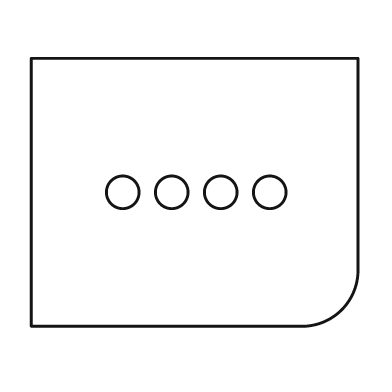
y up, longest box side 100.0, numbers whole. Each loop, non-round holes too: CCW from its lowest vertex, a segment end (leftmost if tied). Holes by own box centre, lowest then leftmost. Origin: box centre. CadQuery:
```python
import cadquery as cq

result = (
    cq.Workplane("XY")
    .moveTo(-50.0, -41.0)
    .lineTo(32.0, -41.0)
    .threePointArc((45.0, -36.0), (50.0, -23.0))
    .lineTo(50.0, 41.0)
    .lineTo(-50.0, 41.0)
    .close()
    .moveTo(-22.0, 0.0)
    .circle(5.0)
    .moveTo(-7.0, 0.0)
    .circle(5.0)
    .moveTo(8.0, 0.0)
    .circle(5.0)
    .moveTo(23.0, 0.0)
    .circle(5.0)
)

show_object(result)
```